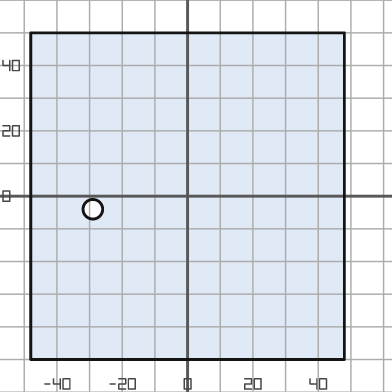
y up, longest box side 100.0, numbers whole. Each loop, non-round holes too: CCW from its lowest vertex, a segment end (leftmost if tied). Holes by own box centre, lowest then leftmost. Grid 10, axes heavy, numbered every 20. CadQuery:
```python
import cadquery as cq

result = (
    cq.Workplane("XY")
    .moveTo(-48.0, -50.0)
    .lineTo(48.0, -50.0)
    .lineTo(48.0, 50.0)
    .lineTo(-48.0, 50.0)
    .close()
    .moveTo(-29.0, -4.0)
    .circle(3.0)
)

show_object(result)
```